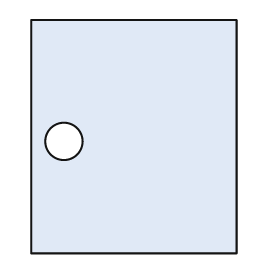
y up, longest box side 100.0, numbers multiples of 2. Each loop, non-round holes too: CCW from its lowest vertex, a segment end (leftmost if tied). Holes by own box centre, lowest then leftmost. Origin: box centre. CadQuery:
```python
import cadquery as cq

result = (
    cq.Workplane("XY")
    .moveTo(-44.0, -50.0)
    .lineTo(44.0, -50.0)
    .lineTo(44.0, 50.0)
    .lineTo(-44.0, 50.0)
    .close()
    .moveTo(-30.0, -2.0)
    .circle(8.0)
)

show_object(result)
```